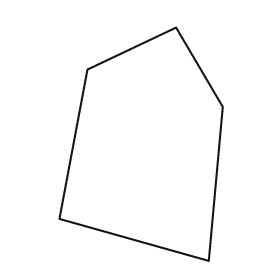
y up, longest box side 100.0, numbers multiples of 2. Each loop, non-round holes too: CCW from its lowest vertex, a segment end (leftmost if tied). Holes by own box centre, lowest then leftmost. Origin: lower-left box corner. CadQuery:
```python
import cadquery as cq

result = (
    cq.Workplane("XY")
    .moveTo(64.0, 0.0)
    .lineTo(70.0, 66.0)
    .lineTo(50.0, 100.0)
    .lineTo(12.0, 82.0)
    .lineTo(0.0, 18.0)
    .close()
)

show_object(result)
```